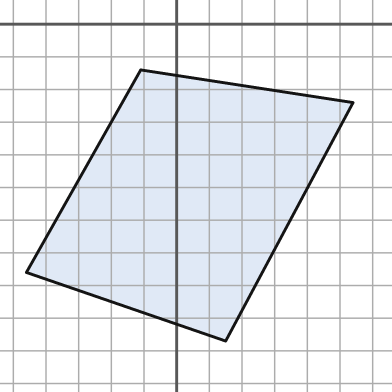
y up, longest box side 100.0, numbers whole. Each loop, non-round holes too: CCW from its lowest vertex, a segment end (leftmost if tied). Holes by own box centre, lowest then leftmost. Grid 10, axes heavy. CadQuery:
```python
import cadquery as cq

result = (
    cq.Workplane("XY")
    .moveTo(15.0, -97.0)
    .lineTo(54.0, -24.0)
    .lineTo(-11.0, -14.0)
    .lineTo(-46.0, -76.0)
    .close()
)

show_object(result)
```